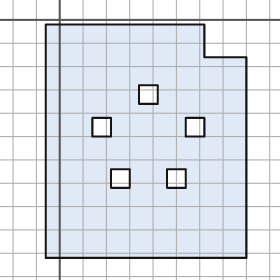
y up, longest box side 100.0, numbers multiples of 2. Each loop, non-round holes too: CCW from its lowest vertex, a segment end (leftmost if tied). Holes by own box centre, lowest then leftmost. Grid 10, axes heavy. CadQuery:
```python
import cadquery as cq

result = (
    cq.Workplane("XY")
    .moveTo(-6.0, -102.0)
    .lineTo(80.0, -102.0)
    .lineTo(80.0, -16.0)
    .lineTo(62.0, -16.0)
    .lineTo(62.0, -2.0)
    .lineTo(-6.0, -2.0)
    .close()
    .moveTo(22.0, -72.0)
    .lineTo(30.0, -72.0)
    .lineTo(30.0, -64.0)
    .lineTo(22.0, -64.0)
    .close()
    .moveTo(46.0, -72.0)
    .lineTo(54.0, -72.0)
    .lineTo(54.0, -64.0)
    .lineTo(46.0, -64.0)
    .close()
    .moveTo(14.0, -50.0)
    .lineTo(22.0, -50.0)
    .lineTo(22.0, -42.0)
    .lineTo(14.0, -42.0)
    .close()
    .moveTo(54.0, -50.0)
    .lineTo(62.0, -50.0)
    .lineTo(62.0, -42.0)
    .lineTo(54.0, -42.0)
    .close()
    .moveTo(34.0, -36.0)
    .lineTo(42.0, -36.0)
    .lineTo(42.0, -28.0)
    .lineTo(34.0, -28.0)
    .close()
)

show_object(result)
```